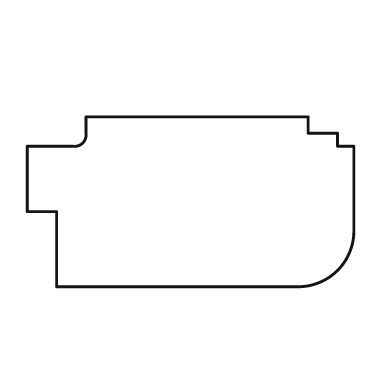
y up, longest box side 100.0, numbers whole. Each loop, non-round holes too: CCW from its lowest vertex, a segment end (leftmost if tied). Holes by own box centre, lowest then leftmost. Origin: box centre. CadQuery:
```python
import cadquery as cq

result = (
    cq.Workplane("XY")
    .moveTo(-41.0, -26.0)
    .lineTo(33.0, -26.0)
    .threePointArc((45.0, -21.0), (50.0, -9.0))
    .lineTo(50.0, 17.0)
    .lineTo(45.0, 17.0)
    .lineTo(45.0, 21.0)
    .lineTo(36.0, 21.0)
    .lineTo(36.0, 26.0)
    .lineTo(-32.0, 26.0)
    .lineTo(-32.0, 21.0)
    .threePointArc((-33.0, 18.0), (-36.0, 17.0))
    .lineTo(-50.0, 17.0)
    .lineTo(-50.0, -3.0)
    .lineTo(-41.0, -3.0)
    .close()
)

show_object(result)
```